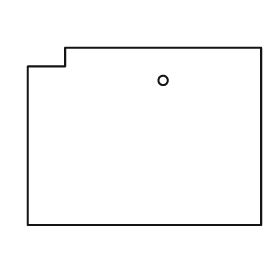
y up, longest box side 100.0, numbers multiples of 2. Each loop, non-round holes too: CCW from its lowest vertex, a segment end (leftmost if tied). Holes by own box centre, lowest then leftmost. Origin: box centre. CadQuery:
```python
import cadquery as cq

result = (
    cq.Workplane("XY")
    .moveTo(-50.0, -38.0)
    .lineTo(50.0, -38.0)
    .lineTo(50.0, 38.0)
    .lineTo(-34.0, 38.0)
    .lineTo(-34.0, 30.0)
    .lineTo(-50.0, 30.0)
    .close()
    .moveTo(8.0, 24.0)
    .circle(2.0)
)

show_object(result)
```